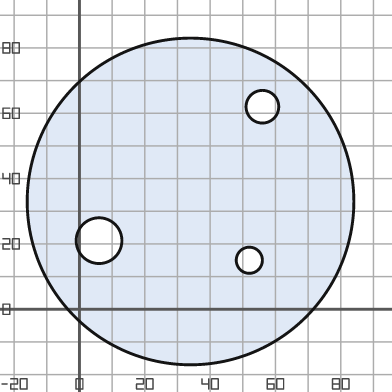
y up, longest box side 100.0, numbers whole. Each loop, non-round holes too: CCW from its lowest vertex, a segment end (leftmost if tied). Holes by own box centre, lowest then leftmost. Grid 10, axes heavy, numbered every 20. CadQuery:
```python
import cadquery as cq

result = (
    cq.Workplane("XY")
    .moveTo(34.0, 33.0)
    .circle(50.0)
    .moveTo(52.0, 15.0)
    .circle(4.0)
    .moveTo(6.0, 21.0)
    .circle(7.0)
    .moveTo(56.0, 62.0)
    .circle(5.0)
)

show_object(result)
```